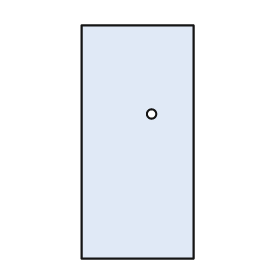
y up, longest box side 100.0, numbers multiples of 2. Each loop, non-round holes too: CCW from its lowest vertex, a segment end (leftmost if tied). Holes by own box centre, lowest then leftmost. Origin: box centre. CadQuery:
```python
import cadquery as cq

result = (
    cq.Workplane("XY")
    .moveTo(-24.0, -50.0)
    .lineTo(24.0, -50.0)
    .lineTo(24.0, 50.0)
    .lineTo(-24.0, 50.0)
    .close()
    .moveTo(6.0, 12.0)
    .circle(2.0)
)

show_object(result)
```